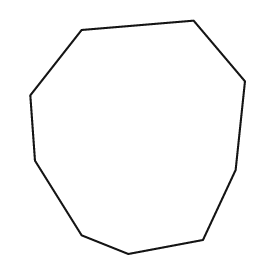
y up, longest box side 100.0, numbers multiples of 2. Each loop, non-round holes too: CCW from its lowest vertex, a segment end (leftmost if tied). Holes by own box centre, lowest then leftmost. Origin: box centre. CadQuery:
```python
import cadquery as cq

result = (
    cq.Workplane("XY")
    .moveTo(-4.0, -50.0)
    .lineTo(28.0, -44.0)
    .lineTo(42.0, -14.0)
    .lineTo(46.0, 24.0)
    .lineTo(24.0, 50.0)
    .lineTo(-24.0, 46.0)
    .lineTo(-46.0, 18.0)
    .lineTo(-44.0, -10.0)
    .lineTo(-24.0, -42.0)
    .close()
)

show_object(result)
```